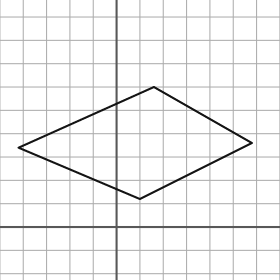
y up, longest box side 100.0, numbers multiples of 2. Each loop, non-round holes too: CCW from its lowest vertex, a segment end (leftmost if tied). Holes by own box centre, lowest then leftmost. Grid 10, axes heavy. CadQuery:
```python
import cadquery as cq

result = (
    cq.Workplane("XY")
    .moveTo(10.0, 12.0)
    .lineTo(58.0, 36.0)
    .lineTo(16.0, 60.0)
    .lineTo(-42.0, 34.0)
    .close()
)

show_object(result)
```